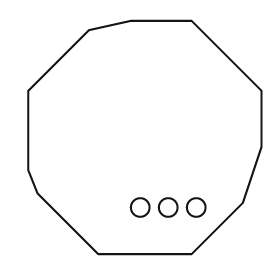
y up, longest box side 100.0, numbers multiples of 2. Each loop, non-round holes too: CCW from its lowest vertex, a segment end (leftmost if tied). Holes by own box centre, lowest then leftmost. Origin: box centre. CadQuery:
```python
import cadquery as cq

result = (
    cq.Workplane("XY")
    .moveTo(-20.0, -50.0)
    .lineTo(20.0, -50.0)
    .lineTo(42.0, -28.0)
    .lineTo(50.0, -4.0)
    .lineTo(50.0, 20.0)
    .lineTo(20.0, 50.0)
    .lineTo(-6.0, 50.0)
    .lineTo(-24.0, 46.0)
    .lineTo(-50.0, 20.0)
    .lineTo(-50.0, -14.0)
    .lineTo(-46.0, -24.0)
    .close()
    .moveTo(-2.0, -30.0)
    .circle(4.0)
    .moveTo(10.0, -30.0)
    .circle(4.0)
    .moveTo(22.0, -30.0)
    .circle(4.0)
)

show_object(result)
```